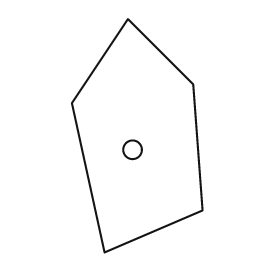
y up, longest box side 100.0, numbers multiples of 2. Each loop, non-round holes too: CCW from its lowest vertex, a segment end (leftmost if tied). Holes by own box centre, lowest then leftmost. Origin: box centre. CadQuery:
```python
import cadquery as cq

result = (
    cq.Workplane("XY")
    .moveTo(-14.0, -50.0)
    .lineTo(28.0, -32.0)
    .lineTo(24.0, 22.0)
    .lineTo(-4.0, 50.0)
    .lineTo(-28.0, 14.0)
    .close()
    .moveTo(-2.0, -6.0)
    .circle(4.0)
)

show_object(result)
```